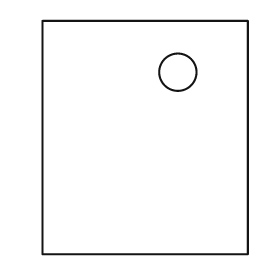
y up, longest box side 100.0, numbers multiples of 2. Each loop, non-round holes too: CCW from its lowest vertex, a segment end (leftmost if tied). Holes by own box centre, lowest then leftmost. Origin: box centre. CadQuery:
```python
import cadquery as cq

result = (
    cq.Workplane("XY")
    .moveTo(-44.0, -50.0)
    .lineTo(44.0, -50.0)
    .lineTo(44.0, 50.0)
    .lineTo(-44.0, 50.0)
    .close()
    .moveTo(14.0, 28.0)
    .circle(8.0)
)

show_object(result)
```